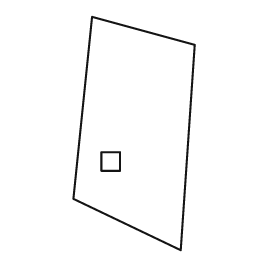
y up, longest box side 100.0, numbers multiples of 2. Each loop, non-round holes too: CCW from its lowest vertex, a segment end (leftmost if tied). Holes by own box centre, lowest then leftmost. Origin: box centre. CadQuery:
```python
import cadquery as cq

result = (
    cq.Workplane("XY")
    .moveTo(20.0, -50.0)
    .lineTo(26.0, 38.0)
    .lineTo(-18.0, 50.0)
    .lineTo(-26.0, -28.0)
    .close()
    .moveTo(-14.0, -16.0)
    .lineTo(-6.0, -16.0)
    .lineTo(-6.0, -8.0)
    .lineTo(-14.0, -8.0)
    .close()
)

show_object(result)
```